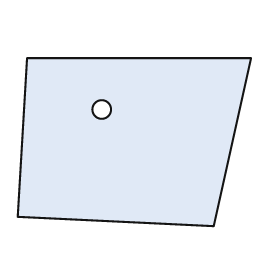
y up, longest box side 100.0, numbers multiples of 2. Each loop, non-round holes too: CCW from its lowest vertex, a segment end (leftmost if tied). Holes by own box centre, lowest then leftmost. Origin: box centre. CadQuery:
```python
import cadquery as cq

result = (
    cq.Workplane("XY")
    .moveTo(34.0, -36.0)
    .lineTo(50.0, 36.0)
    .lineTo(-46.0, 36.0)
    .lineTo(-50.0, -32.0)
    .close()
    .moveTo(-14.0, 14.0)
    .circle(4.0)
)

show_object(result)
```